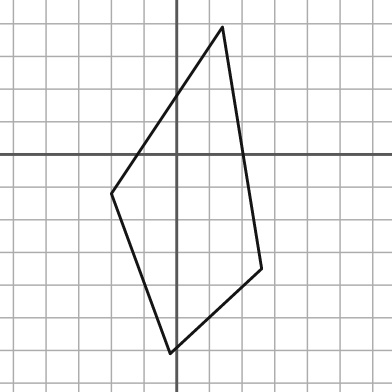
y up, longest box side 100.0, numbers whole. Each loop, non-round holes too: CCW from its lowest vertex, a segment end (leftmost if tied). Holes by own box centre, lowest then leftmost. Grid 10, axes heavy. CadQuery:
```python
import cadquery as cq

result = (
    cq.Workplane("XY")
    .moveTo(-2.0, -61.0)
    .lineTo(26.0, -35.0)
    .lineTo(14.0, 39.0)
    .lineTo(-20.0, -12.0)
    .close()
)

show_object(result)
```